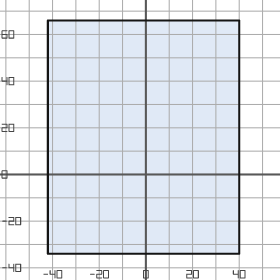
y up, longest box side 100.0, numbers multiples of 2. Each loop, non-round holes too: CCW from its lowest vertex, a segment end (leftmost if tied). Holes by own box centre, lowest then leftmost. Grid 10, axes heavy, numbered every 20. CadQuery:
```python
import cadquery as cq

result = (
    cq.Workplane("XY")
    .moveTo(-42.0, -34.0)
    .lineTo(40.0, -34.0)
    .lineTo(40.0, 66.0)
    .lineTo(-42.0, 66.0)
    .close()
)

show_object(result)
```